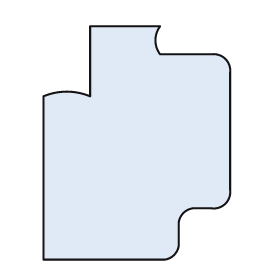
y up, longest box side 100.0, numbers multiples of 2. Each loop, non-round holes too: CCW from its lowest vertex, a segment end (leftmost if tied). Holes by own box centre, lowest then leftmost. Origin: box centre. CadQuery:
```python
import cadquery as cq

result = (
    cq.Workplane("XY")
    .moveTo(-40.0, -50.0)
    .lineTo(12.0, -50.0)
    .threePointArc((16.0, -48.0), (18.0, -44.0))
    .lineTo(18.0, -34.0)
    .threePointArc((20.0, -30.0), (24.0, -28.0))
    .lineTo(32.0, -28.0)
    .threePointArc((38.0, -26.0), (40.0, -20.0))
    .lineTo(40.0, 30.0)
    .threePointArc((38.0, 36.0), (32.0, 38.0))
    .lineTo(10.0, 38.0)
    .threePointArc((8.0, 44.0), (10.0, 50.0))
    .lineTo(-20.0, 50.0)
    .lineTo(-20.0, 20.0)
    .threePointArc((-30.0, 22.0), (-40.0, 20.0))
    .close()
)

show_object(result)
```